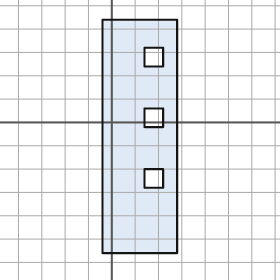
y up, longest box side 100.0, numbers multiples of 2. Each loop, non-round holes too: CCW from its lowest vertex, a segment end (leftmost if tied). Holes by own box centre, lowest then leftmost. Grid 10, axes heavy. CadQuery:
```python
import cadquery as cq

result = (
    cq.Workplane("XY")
    .moveTo(-4.0, -56.0)
    .lineTo(28.0, -56.0)
    .lineTo(28.0, 44.0)
    .lineTo(-4.0, 44.0)
    .close()
    .moveTo(14.0, -28.0)
    .lineTo(22.0, -28.0)
    .lineTo(22.0, -20.0)
    .lineTo(14.0, -20.0)
    .close()
    .moveTo(14.0, -2.0)
    .lineTo(22.0, -2.0)
    .lineTo(22.0, 6.0)
    .lineTo(14.0, 6.0)
    .close()
    .moveTo(14.0, 24.0)
    .lineTo(22.0, 24.0)
    .lineTo(22.0, 32.0)
    .lineTo(14.0, 32.0)
    .close()
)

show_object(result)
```